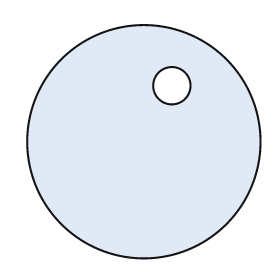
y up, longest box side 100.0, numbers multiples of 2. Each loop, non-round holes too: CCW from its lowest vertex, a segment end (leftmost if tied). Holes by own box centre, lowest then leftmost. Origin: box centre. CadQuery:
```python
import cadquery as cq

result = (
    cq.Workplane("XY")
    .moveTo(0.0, 0.0)
    .circle(50.0)
    .moveTo(12.0, 24.0)
    .circle(8.0)
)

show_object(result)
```